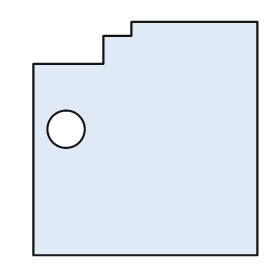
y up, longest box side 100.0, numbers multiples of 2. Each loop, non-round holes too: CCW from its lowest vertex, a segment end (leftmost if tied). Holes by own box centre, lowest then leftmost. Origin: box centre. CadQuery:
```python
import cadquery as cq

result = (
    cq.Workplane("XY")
    .moveTo(-48.0, -50.0)
    .lineTo(48.0, -50.0)
    .lineTo(48.0, 50.0)
    .lineTo(-6.0, 50.0)
    .lineTo(-6.0, 44.0)
    .lineTo(-18.0, 44.0)
    .lineTo(-18.0, 32.0)
    .lineTo(-48.0, 32.0)
    .close()
    .moveTo(-34.0, 4.0)
    .circle(8.0)
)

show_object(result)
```